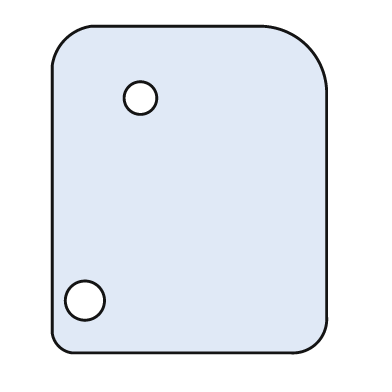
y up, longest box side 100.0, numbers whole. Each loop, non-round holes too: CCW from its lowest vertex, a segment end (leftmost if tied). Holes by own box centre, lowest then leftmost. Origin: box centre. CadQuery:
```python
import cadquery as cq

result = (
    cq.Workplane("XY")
    .moveTo(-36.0, -50.0)
    .lineTo(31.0, -50.0)
    .threePointArc((39.0, -47.0), (42.0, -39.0))
    .lineTo(42.0, 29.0)
    .threePointArc((36.0, 44.0), (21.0, 50.0))
    .lineTo(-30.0, 50.0)
    .threePointArc((-38.0, 46.0), (-42.0, 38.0))
    .lineTo(-42.0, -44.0)
    .threePointArc((-40.0, -48.0), (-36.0, -50.0))
    .close()
    .moveTo(-32.0, -34.0)
    .circle(6.0)
    .moveTo(-15.0, 28.0)
    .circle(5.0)
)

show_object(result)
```